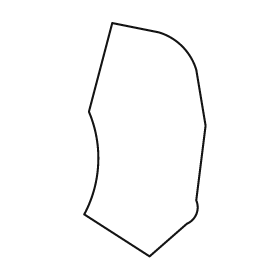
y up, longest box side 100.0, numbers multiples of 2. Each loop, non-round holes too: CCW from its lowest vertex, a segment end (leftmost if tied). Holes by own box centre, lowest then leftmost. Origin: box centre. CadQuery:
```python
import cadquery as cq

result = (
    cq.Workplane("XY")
    .moveTo(2.0, -50.0)
    .lineTo(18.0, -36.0)
    .threePointArc((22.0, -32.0), (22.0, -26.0))
    .lineTo(26.0, 6.0)
    .lineTo(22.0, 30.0)
    .threePointArc((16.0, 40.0), (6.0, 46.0))
    .lineTo(-14.0, 50.0)
    .lineTo(-24.0, 12.0)
    .threePointArc((-20.0, -10.0), (-26.0, -32.0))
    .close()
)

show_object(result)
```